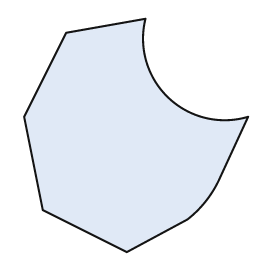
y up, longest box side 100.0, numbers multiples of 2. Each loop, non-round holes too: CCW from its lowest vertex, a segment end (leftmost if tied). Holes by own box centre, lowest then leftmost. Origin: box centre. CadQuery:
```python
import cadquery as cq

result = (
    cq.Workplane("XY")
    .moveTo(-4.0, -50.0)
    .lineTo(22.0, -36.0)
    .threePointArc((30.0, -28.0), (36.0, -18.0))
    .lineTo(48.0, 8.0)
    .threePointArc((14.0, 16.0), (4.0, 50.0))
    .lineTo(-30.0, 44.0)
    .lineTo(-48.0, 8.0)
    .lineTo(-40.0, -32.0)
    .close()
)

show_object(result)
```